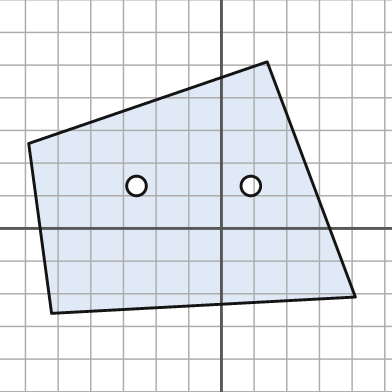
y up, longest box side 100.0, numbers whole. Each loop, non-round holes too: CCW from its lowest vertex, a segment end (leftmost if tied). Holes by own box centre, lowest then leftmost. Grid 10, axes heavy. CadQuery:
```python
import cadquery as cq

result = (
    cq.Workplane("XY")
    .moveTo(-52.0, -26.0)
    .lineTo(41.0, -21.0)
    .lineTo(14.0, 51.0)
    .lineTo(-59.0, 26.0)
    .close()
    .moveTo(-26.0, 13.0)
    .circle(3.0)
    .moveTo(9.0, 13.0)
    .circle(3.0)
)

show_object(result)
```